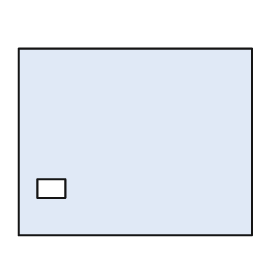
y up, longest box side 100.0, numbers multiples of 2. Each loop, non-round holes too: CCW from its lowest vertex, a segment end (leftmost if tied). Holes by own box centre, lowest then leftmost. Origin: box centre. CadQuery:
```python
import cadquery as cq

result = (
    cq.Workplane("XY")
    .moveTo(-50.0, -40.0)
    .lineTo(50.0, -40.0)
    .lineTo(50.0, 40.0)
    .lineTo(-50.0, 40.0)
    .close()
    .moveTo(-42.0, -24.0)
    .lineTo(-30.0, -24.0)
    .lineTo(-30.0, -16.0)
    .lineTo(-42.0, -16.0)
    .close()
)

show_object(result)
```